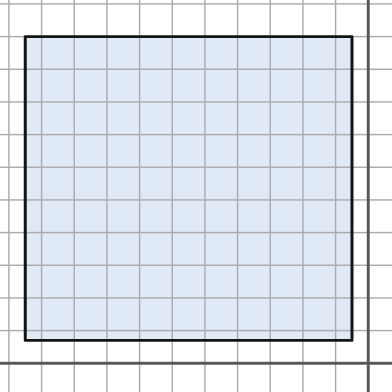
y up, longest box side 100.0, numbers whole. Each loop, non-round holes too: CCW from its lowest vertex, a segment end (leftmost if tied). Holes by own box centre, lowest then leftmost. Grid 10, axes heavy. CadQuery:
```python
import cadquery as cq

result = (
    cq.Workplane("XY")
    .moveTo(-105.0, 7.0)
    .lineTo(-5.0, 7.0)
    .lineTo(-5.0, 100.0)
    .lineTo(-105.0, 100.0)
    .close()
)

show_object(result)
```